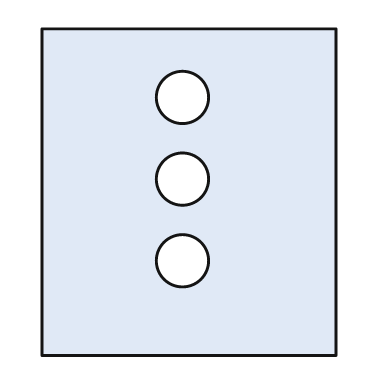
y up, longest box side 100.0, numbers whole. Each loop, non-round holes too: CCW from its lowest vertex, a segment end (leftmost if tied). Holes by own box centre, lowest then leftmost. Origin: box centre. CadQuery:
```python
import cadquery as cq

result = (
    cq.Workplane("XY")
    .moveTo(-45.0, -50.0)
    .lineTo(45.0, -50.0)
    .lineTo(45.0, 50.0)
    .lineTo(-45.0, 50.0)
    .close()
    .moveTo(-2.0, -21.0)
    .circle(8.0)
    .moveTo(-2.0, 4.0)
    .circle(8.0)
    .moveTo(-2.0, 29.0)
    .circle(8.0)
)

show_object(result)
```